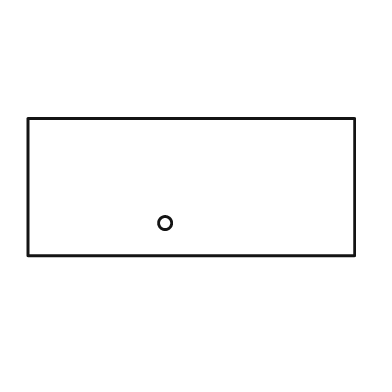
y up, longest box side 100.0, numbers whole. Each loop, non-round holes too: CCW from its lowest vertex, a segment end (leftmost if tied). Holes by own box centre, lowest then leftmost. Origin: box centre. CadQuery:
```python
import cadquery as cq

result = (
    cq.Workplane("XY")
    .moveTo(-50.0, -21.0)
    .lineTo(50.0, -21.0)
    .lineTo(50.0, 21.0)
    .lineTo(-50.0, 21.0)
    .close()
    .moveTo(-8.0, -11.0)
    .circle(2.0)
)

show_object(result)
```